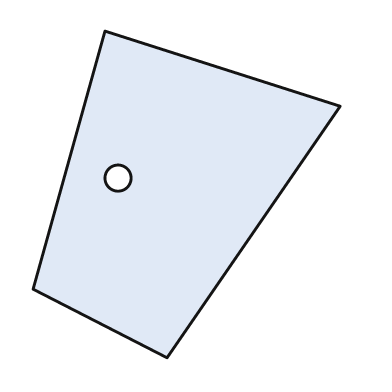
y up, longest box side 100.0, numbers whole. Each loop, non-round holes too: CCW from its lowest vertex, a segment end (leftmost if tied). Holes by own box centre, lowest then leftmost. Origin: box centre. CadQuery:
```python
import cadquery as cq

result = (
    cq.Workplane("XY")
    .moveTo(-6.0, -50.0)
    .lineTo(47.0, 27.0)
    .lineTo(-25.0, 50.0)
    .lineTo(-47.0, -29.0)
    .close()
    .moveTo(-21.0, 5.0)
    .circle(4.0)
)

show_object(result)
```